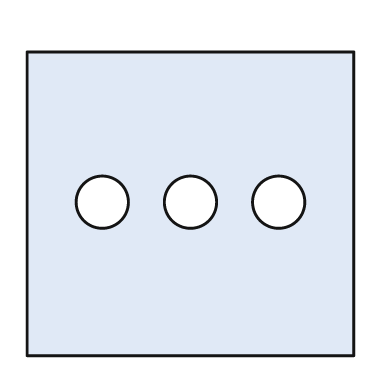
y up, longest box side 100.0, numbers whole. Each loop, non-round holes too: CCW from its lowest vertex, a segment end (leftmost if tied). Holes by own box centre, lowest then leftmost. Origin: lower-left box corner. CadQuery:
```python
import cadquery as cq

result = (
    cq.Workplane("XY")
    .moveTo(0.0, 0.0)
    .lineTo(100.0, 0.0)
    .lineTo(100.0, 93.0)
    .lineTo(0.0, 93.0)
    .close()
    .moveTo(23.0, 47.0)
    .circle(8.0)
    .moveTo(50.0, 47.0)
    .circle(8.0)
    .moveTo(77.0, 47.0)
    .circle(8.0)
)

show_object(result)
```